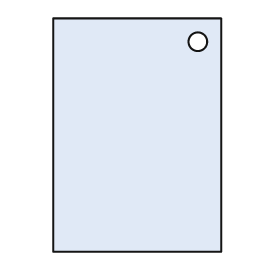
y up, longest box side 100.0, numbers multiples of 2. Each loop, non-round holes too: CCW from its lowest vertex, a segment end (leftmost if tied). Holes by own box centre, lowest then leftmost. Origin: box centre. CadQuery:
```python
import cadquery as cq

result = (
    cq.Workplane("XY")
    .moveTo(-36.0, -50.0)
    .lineTo(36.0, -50.0)
    .lineTo(36.0, 50.0)
    .lineTo(-36.0, 50.0)
    .close()
    .moveTo(26.0, 40.0)
    .circle(4.0)
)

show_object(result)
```